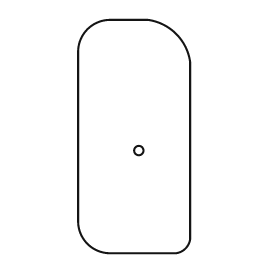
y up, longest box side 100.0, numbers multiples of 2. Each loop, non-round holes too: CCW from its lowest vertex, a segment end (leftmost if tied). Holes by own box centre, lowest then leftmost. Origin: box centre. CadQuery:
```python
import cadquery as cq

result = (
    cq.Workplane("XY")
    .moveTo(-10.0, -50.0)
    .lineTo(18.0, -50.0)
    .threePointArc((22.0, -48.0), (24.0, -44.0))
    .lineTo(24.0, 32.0)
    .threePointArc((18.0, 44.0), (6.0, 50.0))
    .lineTo(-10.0, 50.0)
    .threePointArc((-20.0, 46.0), (-24.0, 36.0))
    .lineTo(-24.0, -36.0)
    .threePointArc((-20.0, -46.0), (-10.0, -50.0))
    .close()
    .moveTo(2.0, -6.0)
    .circle(2.0)
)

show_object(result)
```